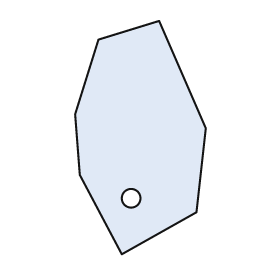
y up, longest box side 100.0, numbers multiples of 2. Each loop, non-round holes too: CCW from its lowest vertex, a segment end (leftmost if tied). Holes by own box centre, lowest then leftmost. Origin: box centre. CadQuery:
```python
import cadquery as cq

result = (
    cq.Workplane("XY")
    .moveTo(-8.0, -50.0)
    .lineTo(24.0, -32.0)
    .lineTo(28.0, 4.0)
    .lineTo(8.0, 50.0)
    .lineTo(-18.0, 42.0)
    .lineTo(-28.0, 10.0)
    .lineTo(-26.0, -16.0)
    .close()
    .moveTo(-4.0, -26.0)
    .circle(4.0)
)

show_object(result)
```